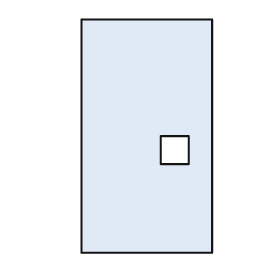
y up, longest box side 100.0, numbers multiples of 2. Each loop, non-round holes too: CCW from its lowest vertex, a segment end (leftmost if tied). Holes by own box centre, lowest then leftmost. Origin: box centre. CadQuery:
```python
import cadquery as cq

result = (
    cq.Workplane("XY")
    .moveTo(-28.0, -50.0)
    .lineTo(28.0, -50.0)
    .lineTo(28.0, 50.0)
    .lineTo(-28.0, 50.0)
    .close()
    .moveTo(6.0, -12.0)
    .lineTo(18.0, -12.0)
    .lineTo(18.0, 0.0)
    .lineTo(6.0, 0.0)
    .close()
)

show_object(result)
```